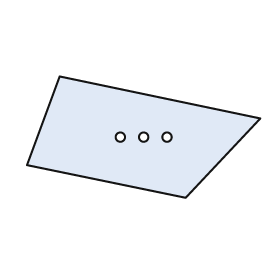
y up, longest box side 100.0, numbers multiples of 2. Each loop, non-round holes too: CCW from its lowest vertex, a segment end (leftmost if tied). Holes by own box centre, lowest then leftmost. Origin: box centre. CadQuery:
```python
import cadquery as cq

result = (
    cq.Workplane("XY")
    .moveTo(18.0, -26.0)
    .lineTo(50.0, 8.0)
    .lineTo(-36.0, 26.0)
    .lineTo(-50.0, -12.0)
    .close()
    .moveTo(-10.0, 0.0)
    .circle(2.0)
    .moveTo(0.0, 0.0)
    .circle(2.0)
    .moveTo(10.0, 0.0)
    .circle(2.0)
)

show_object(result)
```